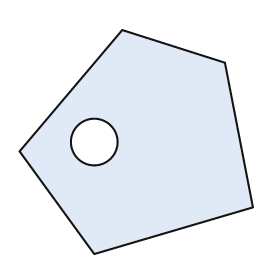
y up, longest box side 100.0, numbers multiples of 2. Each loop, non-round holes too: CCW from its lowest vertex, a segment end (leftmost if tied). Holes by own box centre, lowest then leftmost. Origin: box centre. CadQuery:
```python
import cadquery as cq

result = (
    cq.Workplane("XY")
    .moveTo(-18.0, -48.0)
    .lineTo(50.0, -28.0)
    .lineTo(38.0, 34.0)
    .lineTo(-6.0, 48.0)
    .lineTo(-50.0, -4.0)
    .close()
    .moveTo(-18.0, 0.0)
    .circle(10.0)
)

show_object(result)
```